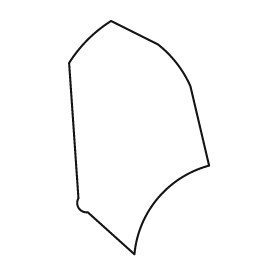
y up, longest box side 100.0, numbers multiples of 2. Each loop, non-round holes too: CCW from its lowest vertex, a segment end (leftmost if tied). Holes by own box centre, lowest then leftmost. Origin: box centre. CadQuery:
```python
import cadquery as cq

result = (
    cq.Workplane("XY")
    .moveTo(-2.0, -50.0)
    .threePointArc((8.0, -26.0), (30.0, -12.0))
    .lineTo(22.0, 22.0)
    .threePointArc((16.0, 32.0), (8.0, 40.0))
    .lineTo(-12.0, 50.0)
    .threePointArc((-22.0, 42.0), (-30.0, 32.0))
    .lineTo(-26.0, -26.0)
    .threePointArc((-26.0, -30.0), (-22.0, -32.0))
    .close()
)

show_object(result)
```